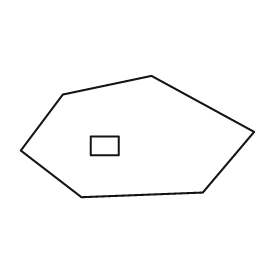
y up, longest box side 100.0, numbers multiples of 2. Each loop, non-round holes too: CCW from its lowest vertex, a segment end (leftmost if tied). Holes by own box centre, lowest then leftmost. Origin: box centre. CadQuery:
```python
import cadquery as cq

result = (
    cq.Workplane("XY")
    .moveTo(-24.0, -26.0)
    .lineTo(28.0, -24.0)
    .lineTo(50.0, 2.0)
    .lineTo(6.0, 26.0)
    .lineTo(-32.0, 18.0)
    .lineTo(-50.0, -6.0)
    .close()
    .moveTo(-20.0, -8.0)
    .lineTo(-8.0, -8.0)
    .lineTo(-8.0, 0.0)
    .lineTo(-20.0, 0.0)
    .close()
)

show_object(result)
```